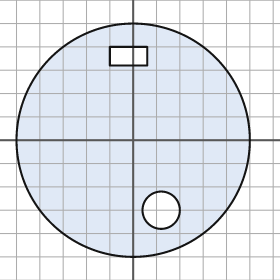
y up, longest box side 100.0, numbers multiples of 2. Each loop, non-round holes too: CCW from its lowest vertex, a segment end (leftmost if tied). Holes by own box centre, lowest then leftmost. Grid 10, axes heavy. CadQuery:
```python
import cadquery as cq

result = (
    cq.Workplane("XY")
    .moveTo(0.0, 0.0)
    .circle(50.0)
    .moveTo(12.0, -30.0)
    .circle(8.0)
    .moveTo(-10.0, 32.0)
    .lineTo(6.0, 32.0)
    .lineTo(6.0, 40.0)
    .lineTo(-10.0, 40.0)
    .close()
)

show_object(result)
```